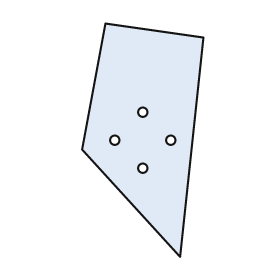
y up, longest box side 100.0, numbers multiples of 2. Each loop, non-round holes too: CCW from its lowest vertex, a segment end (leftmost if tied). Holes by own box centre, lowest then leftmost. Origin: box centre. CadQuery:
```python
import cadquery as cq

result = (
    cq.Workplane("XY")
    .moveTo(16.0, -50.0)
    .lineTo(26.0, 44.0)
    .lineTo(-16.0, 50.0)
    .lineTo(-26.0, -4.0)
    .close()
    .moveTo(0.0, -12.0)
    .circle(2.0)
    .moveTo(-12.0, 0.0)
    .circle(2.0)
    .moveTo(12.0, 0.0)
    .circle(2.0)
    .moveTo(0.0, 12.0)
    .circle(2.0)
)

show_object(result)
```